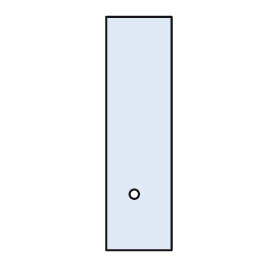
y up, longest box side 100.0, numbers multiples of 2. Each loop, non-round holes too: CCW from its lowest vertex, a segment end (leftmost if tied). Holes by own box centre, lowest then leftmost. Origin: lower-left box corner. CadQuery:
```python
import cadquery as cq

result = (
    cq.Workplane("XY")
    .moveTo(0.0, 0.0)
    .lineTo(28.0, 0.0)
    .lineTo(28.0, 100.0)
    .lineTo(0.0, 100.0)
    .close()
    .moveTo(12.0, 24.0)
    .circle(2.0)
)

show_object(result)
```